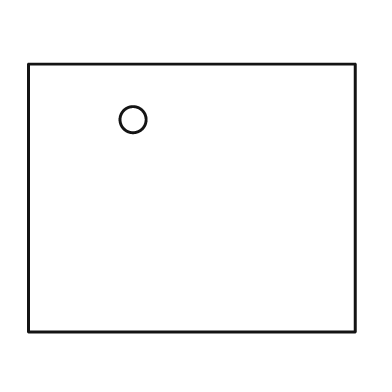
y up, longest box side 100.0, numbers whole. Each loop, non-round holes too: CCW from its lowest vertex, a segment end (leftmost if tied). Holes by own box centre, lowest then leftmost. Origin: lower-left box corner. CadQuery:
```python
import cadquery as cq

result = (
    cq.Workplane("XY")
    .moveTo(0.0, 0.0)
    .lineTo(100.0, 0.0)
    .lineTo(100.0, 82.0)
    .lineTo(0.0, 82.0)
    .close()
    .moveTo(32.0, 65.0)
    .circle(4.0)
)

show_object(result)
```